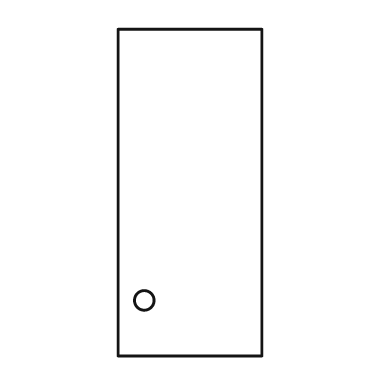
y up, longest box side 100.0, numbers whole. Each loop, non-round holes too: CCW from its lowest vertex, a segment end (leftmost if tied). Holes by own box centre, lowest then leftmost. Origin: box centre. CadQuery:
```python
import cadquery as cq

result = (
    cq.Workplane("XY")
    .moveTo(-22.0, -50.0)
    .lineTo(22.0, -50.0)
    .lineTo(22.0, 50.0)
    .lineTo(-22.0, 50.0)
    .close()
    .moveTo(-14.0, -33.0)
    .circle(3.0)
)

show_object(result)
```